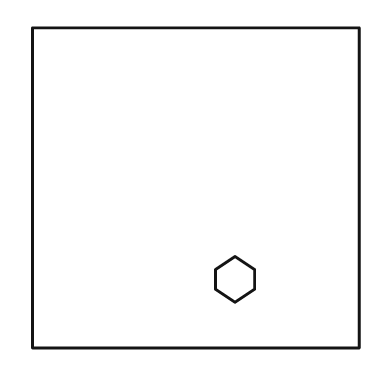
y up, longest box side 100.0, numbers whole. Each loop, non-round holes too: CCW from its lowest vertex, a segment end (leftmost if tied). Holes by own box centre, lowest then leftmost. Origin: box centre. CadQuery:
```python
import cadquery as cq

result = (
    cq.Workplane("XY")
    .moveTo(-50.0, -49.0)
    .lineTo(50.0, -49.0)
    .lineTo(50.0, 49.0)
    .lineTo(-50.0, 49.0)
    .close()
    .moveTo(12.0, -35.0)
    .lineTo(18.0, -31.0)
    .lineTo(18.0, -25.0)
    .lineTo(12.0, -21.0)
    .lineTo(6.0, -25.0)
    .lineTo(6.0, -31.0)
    .close()
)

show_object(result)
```